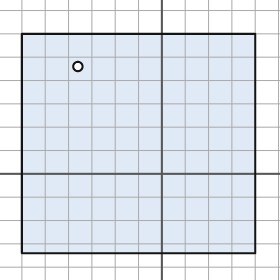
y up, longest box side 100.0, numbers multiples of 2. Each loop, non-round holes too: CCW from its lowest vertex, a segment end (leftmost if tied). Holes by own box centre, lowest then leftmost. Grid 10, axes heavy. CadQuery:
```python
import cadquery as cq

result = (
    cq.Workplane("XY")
    .moveTo(-60.0, -34.0)
    .lineTo(40.0, -34.0)
    .lineTo(40.0, 60.0)
    .lineTo(-60.0, 60.0)
    .close()
    .moveTo(-36.0, 46.0)
    .circle(2.0)
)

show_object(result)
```